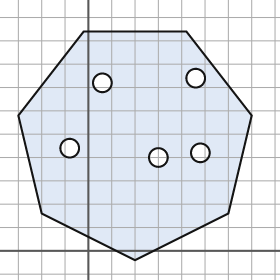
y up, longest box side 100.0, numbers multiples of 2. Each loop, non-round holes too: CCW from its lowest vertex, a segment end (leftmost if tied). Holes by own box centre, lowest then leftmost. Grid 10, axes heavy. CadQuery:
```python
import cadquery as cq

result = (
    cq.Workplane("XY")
    .moveTo(20.0, -4.0)
    .lineTo(60.0, 16.0)
    .lineTo(70.0, 58.0)
    .lineTo(42.0, 94.0)
    .lineTo(-2.0, 94.0)
    .lineTo(-30.0, 58.0)
    .lineTo(-20.0, 16.0)
    .close()
    .moveTo(30.0, 40.0)
    .circle(4.0)
    .moveTo(48.0, 42.0)
    .circle(4.0)
    .moveTo(-8.0, 44.0)
    .circle(4.0)
    .moveTo(6.0, 72.0)
    .circle(4.0)
    .moveTo(46.0, 74.0)
    .circle(4.0)
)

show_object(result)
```